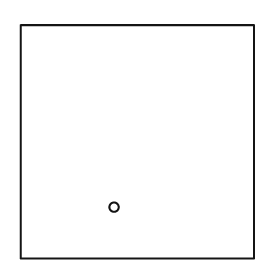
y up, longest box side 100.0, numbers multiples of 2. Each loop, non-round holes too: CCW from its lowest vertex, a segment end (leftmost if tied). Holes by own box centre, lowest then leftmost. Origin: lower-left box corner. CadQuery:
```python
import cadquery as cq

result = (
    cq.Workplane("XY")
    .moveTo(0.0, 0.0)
    .lineTo(100.0, 0.0)
    .lineTo(100.0, 100.0)
    .lineTo(0.0, 100.0)
    .close()
    .moveTo(40.0, 22.0)
    .circle(2.0)
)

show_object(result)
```